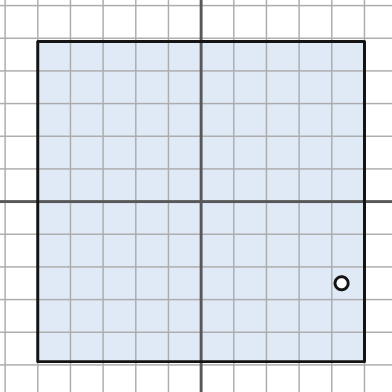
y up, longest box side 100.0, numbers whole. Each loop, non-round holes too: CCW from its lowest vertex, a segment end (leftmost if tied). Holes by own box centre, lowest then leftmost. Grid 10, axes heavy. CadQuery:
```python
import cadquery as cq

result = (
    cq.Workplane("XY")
    .moveTo(-50.0, -49.0)
    .lineTo(50.0, -49.0)
    .lineTo(50.0, 49.0)
    .lineTo(-50.0, 49.0)
    .close()
    .moveTo(43.0, -25.0)
    .circle(2.0)
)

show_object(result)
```